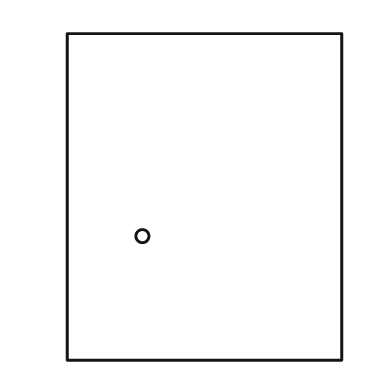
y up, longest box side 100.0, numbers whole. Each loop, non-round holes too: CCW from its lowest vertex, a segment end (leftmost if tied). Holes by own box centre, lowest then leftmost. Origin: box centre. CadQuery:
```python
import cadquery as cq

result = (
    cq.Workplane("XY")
    .moveTo(-42.0, -50.0)
    .lineTo(42.0, -50.0)
    .lineTo(42.0, 50.0)
    .lineTo(-42.0, 50.0)
    .close()
    .moveTo(-19.0, -12.0)
    .circle(2.0)
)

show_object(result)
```